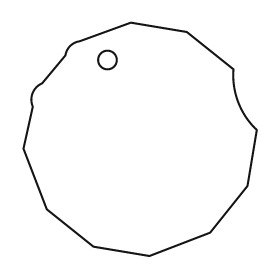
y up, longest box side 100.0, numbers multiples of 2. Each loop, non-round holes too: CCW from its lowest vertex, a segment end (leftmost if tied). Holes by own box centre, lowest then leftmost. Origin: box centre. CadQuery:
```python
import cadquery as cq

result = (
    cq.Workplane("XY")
    .moveTo(4.0, -50.0)
    .lineTo(30.0, -40.0)
    .lineTo(46.0, -20.0)
    .lineTo(50.0, 4.0)
    .threePointArc((42.0, 16.0), (40.0, 30.0))
    .lineTo(20.0, 46.0)
    .lineTo(-4.0, 50.0)
    .lineTo(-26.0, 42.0)
    .threePointArc((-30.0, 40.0), (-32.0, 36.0))
    .lineTo(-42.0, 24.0)
    .threePointArc((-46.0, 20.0), (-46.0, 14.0))
    .lineTo(-50.0, -4.0)
    .lineTo(-40.0, -30.0)
    .lineTo(-20.0, -46.0)
    .close()
    .moveTo(-14.0, 34.0)
    .circle(4.0)
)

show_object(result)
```